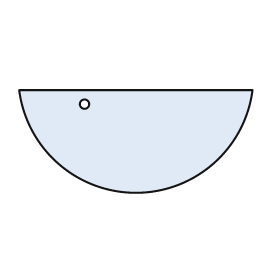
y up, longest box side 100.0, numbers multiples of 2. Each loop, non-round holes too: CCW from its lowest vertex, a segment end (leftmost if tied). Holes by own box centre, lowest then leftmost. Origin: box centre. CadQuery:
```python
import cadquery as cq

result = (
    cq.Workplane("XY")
    .moveTo(-50.0, 22.0)
    .threePointArc((0.0, -22.0), (50.0, 22.0))
    .close()
    .moveTo(-22.0, 16.0)
    .circle(2.0)
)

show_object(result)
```